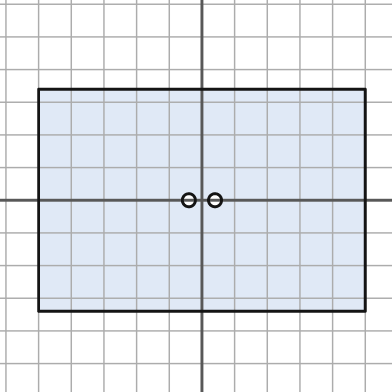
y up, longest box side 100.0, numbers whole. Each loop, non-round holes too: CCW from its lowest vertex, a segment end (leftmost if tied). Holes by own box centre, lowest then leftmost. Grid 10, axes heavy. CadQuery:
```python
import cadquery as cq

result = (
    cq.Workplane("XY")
    .moveTo(-50.0, -34.0)
    .lineTo(50.0, -34.0)
    .lineTo(50.0, 34.0)
    .lineTo(-50.0, 34.0)
    .close()
    .moveTo(-4.0, 0.0)
    .circle(2.0)
    .moveTo(4.0, 0.0)
    .circle(2.0)
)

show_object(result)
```